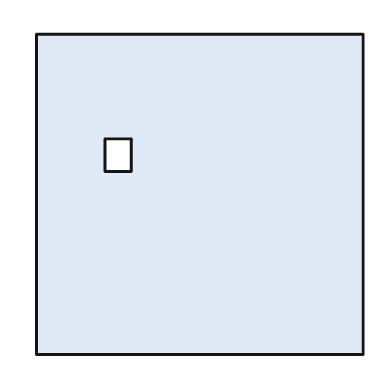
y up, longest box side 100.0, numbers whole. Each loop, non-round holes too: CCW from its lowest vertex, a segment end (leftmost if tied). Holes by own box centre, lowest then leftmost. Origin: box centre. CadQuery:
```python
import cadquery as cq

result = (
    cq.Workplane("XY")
    .moveTo(-50.0, -49.0)
    .lineTo(50.0, -49.0)
    .lineTo(50.0, 49.0)
    .lineTo(-50.0, 49.0)
    .close()
    .moveTo(-29.0, 7.0)
    .lineTo(-21.0, 7.0)
    .lineTo(-21.0, 17.0)
    .lineTo(-29.0, 17.0)
    .close()
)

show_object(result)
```